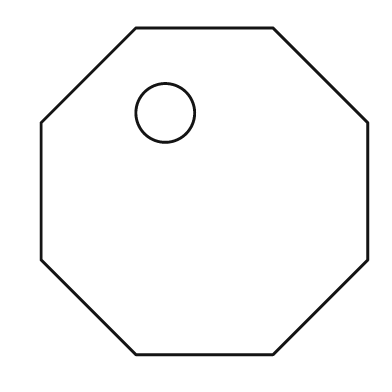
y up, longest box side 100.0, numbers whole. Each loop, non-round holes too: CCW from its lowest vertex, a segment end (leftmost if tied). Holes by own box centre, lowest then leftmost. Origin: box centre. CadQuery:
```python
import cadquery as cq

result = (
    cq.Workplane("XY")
    .moveTo(-21.0, -50.0)
    .lineTo(21.0, -50.0)
    .lineTo(50.0, -21.0)
    .lineTo(50.0, 21.0)
    .lineTo(21.0, 50.0)
    .lineTo(-21.0, 50.0)
    .lineTo(-50.0, 21.0)
    .lineTo(-50.0, -21.0)
    .close()
    .moveTo(-12.0, 24.0)
    .circle(9.0)
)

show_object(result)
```